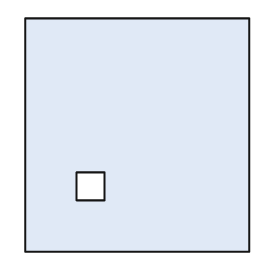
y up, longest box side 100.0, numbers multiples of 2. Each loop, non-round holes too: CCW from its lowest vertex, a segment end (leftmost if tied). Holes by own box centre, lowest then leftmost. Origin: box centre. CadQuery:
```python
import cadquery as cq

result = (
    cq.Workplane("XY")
    .moveTo(-48.0, -50.0)
    .lineTo(48.0, -50.0)
    .lineTo(48.0, 50.0)
    .lineTo(-48.0, 50.0)
    .close()
    .moveTo(-26.0, -28.0)
    .lineTo(-14.0, -28.0)
    .lineTo(-14.0, -16.0)
    .lineTo(-26.0, -16.0)
    .close()
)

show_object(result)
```